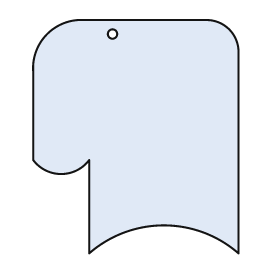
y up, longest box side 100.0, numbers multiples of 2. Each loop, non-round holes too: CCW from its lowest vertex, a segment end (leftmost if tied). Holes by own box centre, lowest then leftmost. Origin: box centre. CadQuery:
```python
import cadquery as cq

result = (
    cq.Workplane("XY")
    .moveTo(-20.0, -50.0)
    .threePointArc((12.0, -38.0), (44.0, -50.0))
    .lineTo(44.0, 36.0)
    .threePointArc((40.0, 46.0), (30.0, 50.0))
    .lineTo(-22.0, 50.0)
    .threePointArc((-38.0, 44.0), (-44.0, 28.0))
    .lineTo(-44.0, -10.0)
    .threePointArc((-32.0, -16.0), (-20.0, -10.0))
    .close()
    .moveTo(-10.0, 44.0)
    .circle(2.0)
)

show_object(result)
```